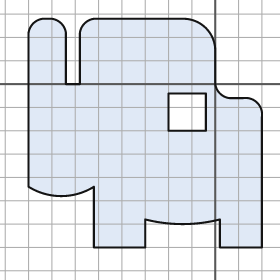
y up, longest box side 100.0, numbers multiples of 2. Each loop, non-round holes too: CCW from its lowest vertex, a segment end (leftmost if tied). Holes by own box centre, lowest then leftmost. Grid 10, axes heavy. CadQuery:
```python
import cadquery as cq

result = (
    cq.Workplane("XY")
    .moveTo(-52.0, -70.0)
    .lineTo(-30.0, -70.0)
    .lineTo(-30.0, -58.0)
    .threePointArc((-14.0, -60.0), (2.0, -58.0))
    .lineTo(2.0, -70.0)
    .lineTo(20.0, -70.0)
    .lineTo(20.0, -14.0)
    .threePointArc((18.0, -8.0), (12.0, -6.0))
    .lineTo(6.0, -6.0)
    .threePointArc((2.0, -4.0), (0.0, 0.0))
    .lineTo(0.0, 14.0)
    .threePointArc((-4.0, 24.0), (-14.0, 28.0))
    .lineTo(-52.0, 28.0)
    .threePointArc((-56.0, 26.0), (-58.0, 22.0))
    .lineTo(-58.0, 0.0)
    .lineTo(-64.0, 0.0)
    .lineTo(-64.0, 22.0)
    .threePointArc((-66.0, 26.0), (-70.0, 28.0))
    .lineTo(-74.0, 28.0)
    .threePointArc((-78.0, 26.0), (-80.0, 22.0))
    .lineTo(-80.0, -44.0)
    .threePointArc((-66.0, -48.0), (-52.0, -44.0))
    .close()
    .moveTo(-20.0, -20.0)
    .lineTo(-4.0, -20.0)
    .lineTo(-4.0, -4.0)
    .lineTo(-20.0, -4.0)
    .close()
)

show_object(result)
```